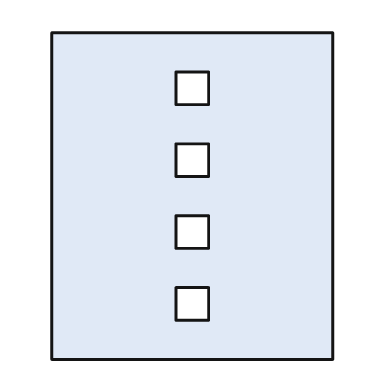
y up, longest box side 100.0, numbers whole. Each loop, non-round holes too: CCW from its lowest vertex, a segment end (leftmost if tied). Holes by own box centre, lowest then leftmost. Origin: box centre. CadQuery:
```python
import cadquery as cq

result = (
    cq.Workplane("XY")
    .moveTo(-43.0, -50.0)
    .lineTo(43.0, -50.0)
    .lineTo(43.0, 50.0)
    .lineTo(-43.0, 50.0)
    .close()
    .moveTo(-5.0, -38.0)
    .lineTo(5.0, -38.0)
    .lineTo(5.0, -28.0)
    .lineTo(-5.0, -28.0)
    .close()
    .moveTo(-5.0, -16.0)
    .lineTo(5.0, -16.0)
    .lineTo(5.0, -6.0)
    .lineTo(-5.0, -6.0)
    .close()
    .moveTo(-5.0, 6.0)
    .lineTo(5.0, 6.0)
    .lineTo(5.0, 16.0)
    .lineTo(-5.0, 16.0)
    .close()
    .moveTo(-5.0, 28.0)
    .lineTo(5.0, 28.0)
    .lineTo(5.0, 38.0)
    .lineTo(-5.0, 38.0)
    .close()
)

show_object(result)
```